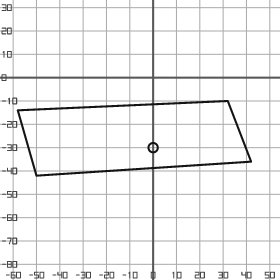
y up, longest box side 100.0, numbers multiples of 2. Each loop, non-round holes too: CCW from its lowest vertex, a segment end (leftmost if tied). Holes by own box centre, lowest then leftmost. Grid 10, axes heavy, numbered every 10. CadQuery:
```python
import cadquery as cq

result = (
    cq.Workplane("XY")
    .moveTo(-50.0, -42.0)
    .lineTo(42.0, -36.0)
    .lineTo(32.0, -10.0)
    .lineTo(-58.0, -14.0)
    .close()
    .moveTo(0.0, -30.0)
    .circle(2.0)
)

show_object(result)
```